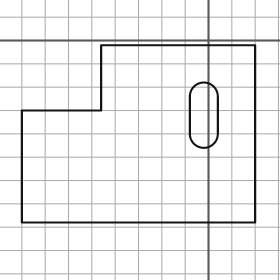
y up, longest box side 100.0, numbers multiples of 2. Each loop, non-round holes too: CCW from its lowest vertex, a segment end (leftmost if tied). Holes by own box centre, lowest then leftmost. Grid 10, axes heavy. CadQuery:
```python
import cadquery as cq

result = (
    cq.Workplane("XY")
    .moveTo(-80.0, -78.0)
    .lineTo(20.0, -78.0)
    .lineTo(20.0, -2.0)
    .lineTo(-46.0, -2.0)
    .lineTo(-46.0, -30.0)
    .lineTo(-80.0, -30.0)
    .close()
    .moveTo(-8.0, -40.0)
    .threePointArc((-2.0, -46.0), (4.0, -40.0))
    .lineTo(4.0, -24.0)
    .threePointArc((-2.0, -18.0), (-8.0, -24.0))
    .close()
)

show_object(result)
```